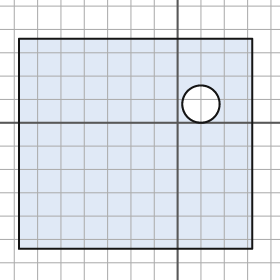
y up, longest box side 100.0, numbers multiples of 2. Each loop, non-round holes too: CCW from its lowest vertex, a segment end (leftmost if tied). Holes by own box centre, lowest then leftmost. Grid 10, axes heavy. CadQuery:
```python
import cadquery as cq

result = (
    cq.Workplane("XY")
    .moveTo(-68.0, -54.0)
    .lineTo(32.0, -54.0)
    .lineTo(32.0, 36.0)
    .lineTo(-68.0, 36.0)
    .close()
    .moveTo(10.0, 8.0)
    .circle(8.0)
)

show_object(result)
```